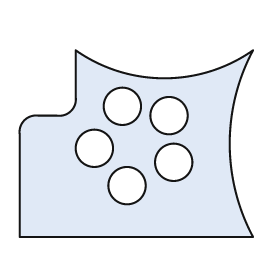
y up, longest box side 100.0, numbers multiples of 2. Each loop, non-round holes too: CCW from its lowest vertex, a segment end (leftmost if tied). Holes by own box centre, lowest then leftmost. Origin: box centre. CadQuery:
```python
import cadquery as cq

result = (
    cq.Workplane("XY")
    .moveTo(-50.0, -40.0)
    .lineTo(50.0, -40.0)
    .threePointArc((40.0, 0.0), (50.0, 40.0))
    .threePointArc((12.0, 28.0), (-26.0, 40.0))
    .lineTo(-26.0, 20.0)
    .threePointArc((-28.0, 14.0), (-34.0, 12.0))
    .lineTo(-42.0, 12.0)
    .threePointArc((-48.0, 10.0), (-50.0, 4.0))
    .close()
    .moveTo(-4.0, -18.0)
    .circle(8.0)
    .moveTo(16.0, -8.0)
    .circle(8.0)
    .moveTo(-18.0, -2.0)
    .circle(8.0)
    .moveTo(14.0, 12.0)
    .circle(8.0)
    .moveTo(-6.0, 16.0)
    .circle(8.0)
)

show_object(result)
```